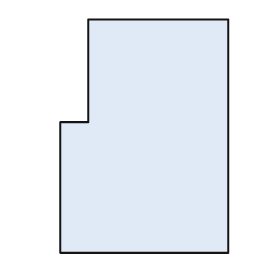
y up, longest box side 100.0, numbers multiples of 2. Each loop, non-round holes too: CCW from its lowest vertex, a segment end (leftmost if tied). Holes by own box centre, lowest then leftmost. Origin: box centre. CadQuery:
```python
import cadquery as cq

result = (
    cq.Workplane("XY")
    .moveTo(-36.0, -50.0)
    .lineTo(36.0, -50.0)
    .lineTo(36.0, 50.0)
    .lineTo(-24.0, 50.0)
    .lineTo(-24.0, 6.0)
    .lineTo(-36.0, 6.0)
    .close()
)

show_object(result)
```